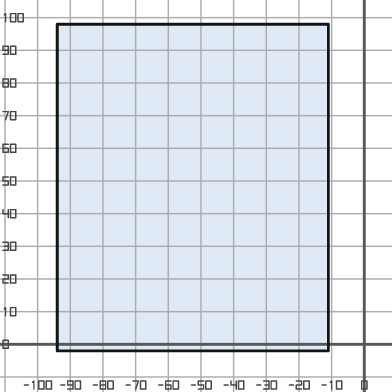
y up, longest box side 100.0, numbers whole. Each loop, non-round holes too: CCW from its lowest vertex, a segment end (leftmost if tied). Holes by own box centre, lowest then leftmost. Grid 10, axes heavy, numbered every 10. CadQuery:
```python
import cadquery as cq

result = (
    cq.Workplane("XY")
    .moveTo(-94.0, -2.0)
    .lineTo(-11.0, -2.0)
    .lineTo(-11.0, 98.0)
    .lineTo(-94.0, 98.0)
    .close()
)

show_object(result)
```